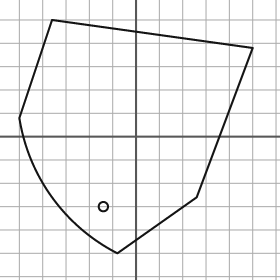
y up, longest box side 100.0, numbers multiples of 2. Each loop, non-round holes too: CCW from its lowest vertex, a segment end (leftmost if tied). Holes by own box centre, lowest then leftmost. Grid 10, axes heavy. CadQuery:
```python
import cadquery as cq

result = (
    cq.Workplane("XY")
    .moveTo(-8.0, -50.0)
    .lineTo(26.0, -26.0)
    .lineTo(50.0, 38.0)
    .lineTo(-36.0, 50.0)
    .lineTo(-50.0, 8.0)
    .threePointArc((-36.0, -26.0), (-8.0, -50.0))
    .close()
    .moveTo(-14.0, -30.0)
    .circle(2.0)
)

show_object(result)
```